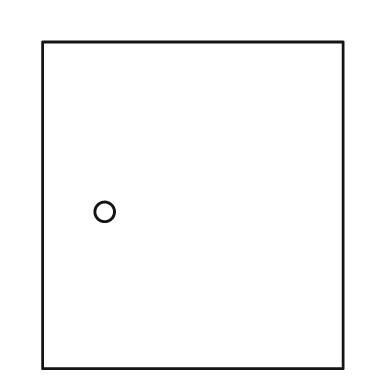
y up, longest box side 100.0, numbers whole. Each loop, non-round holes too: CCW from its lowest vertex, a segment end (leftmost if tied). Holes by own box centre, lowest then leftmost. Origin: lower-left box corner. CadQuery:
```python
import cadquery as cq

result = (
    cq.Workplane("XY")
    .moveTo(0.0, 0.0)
    .lineTo(92.0, 0.0)
    .lineTo(92.0, 100.0)
    .lineTo(0.0, 100.0)
    .close()
    .moveTo(19.0, 48.0)
    .circle(3.0)
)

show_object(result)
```